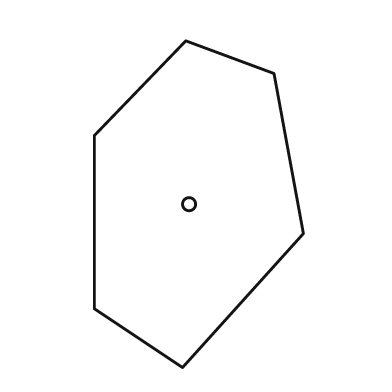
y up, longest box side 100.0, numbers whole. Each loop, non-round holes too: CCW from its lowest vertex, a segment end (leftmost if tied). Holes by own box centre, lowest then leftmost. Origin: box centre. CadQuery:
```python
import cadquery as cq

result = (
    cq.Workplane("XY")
    .moveTo(-5.0, -50.0)
    .lineTo(32.0, -9.0)
    .lineTo(23.0, 40.0)
    .lineTo(-4.0, 50.0)
    .lineTo(-32.0, 21.0)
    .lineTo(-32.0, -32.0)
    .close()
    .moveTo(-3.0, 0.0)
    .circle(2.0)
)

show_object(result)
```